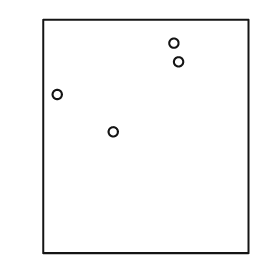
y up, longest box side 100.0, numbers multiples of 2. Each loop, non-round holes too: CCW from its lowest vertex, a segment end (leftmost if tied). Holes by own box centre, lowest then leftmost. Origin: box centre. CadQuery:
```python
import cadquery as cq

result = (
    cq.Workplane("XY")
    .moveTo(-44.0, -50.0)
    .lineTo(44.0, -50.0)
    .lineTo(44.0, 50.0)
    .lineTo(-44.0, 50.0)
    .close()
    .moveTo(-14.0, 2.0)
    .circle(2.0)
    .moveTo(-38.0, 18.0)
    .circle(2.0)
    .moveTo(14.0, 32.0)
    .circle(2.0)
    .moveTo(12.0, 40.0)
    .circle(2.0)
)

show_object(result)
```